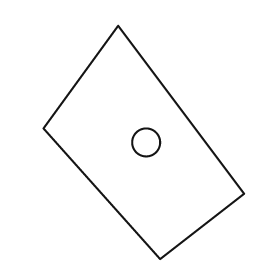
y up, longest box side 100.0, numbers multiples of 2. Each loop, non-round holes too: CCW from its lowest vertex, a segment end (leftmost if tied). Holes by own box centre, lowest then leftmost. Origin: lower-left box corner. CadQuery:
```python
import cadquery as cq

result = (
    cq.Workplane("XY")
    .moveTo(50.0, 0.0)
    .lineTo(86.0, 28.0)
    .lineTo(32.0, 100.0)
    .lineTo(0.0, 56.0)
    .close()
    .moveTo(44.0, 50.0)
    .circle(6.0)
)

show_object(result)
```